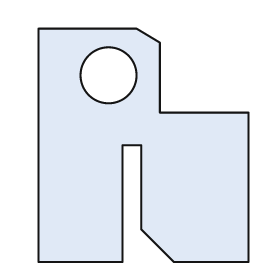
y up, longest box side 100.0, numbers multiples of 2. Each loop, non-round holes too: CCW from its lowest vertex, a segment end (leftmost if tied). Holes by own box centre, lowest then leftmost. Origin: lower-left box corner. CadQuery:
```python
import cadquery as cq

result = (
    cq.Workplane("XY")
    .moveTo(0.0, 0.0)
    .lineTo(36.0, 0.0)
    .lineTo(36.0, 50.0)
    .lineTo(44.0, 50.0)
    .lineTo(44.0, 14.0)
    .lineTo(58.0, 0.0)
    .lineTo(90.0, 0.0)
    .lineTo(90.0, 64.0)
    .lineTo(52.0, 64.0)
    .lineTo(52.0, 94.0)
    .lineTo(42.0, 100.0)
    .lineTo(0.0, 100.0)
    .close()
    .moveTo(30.0, 80.0)
    .circle(12.0)
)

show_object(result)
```